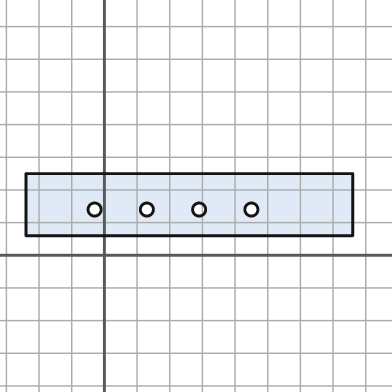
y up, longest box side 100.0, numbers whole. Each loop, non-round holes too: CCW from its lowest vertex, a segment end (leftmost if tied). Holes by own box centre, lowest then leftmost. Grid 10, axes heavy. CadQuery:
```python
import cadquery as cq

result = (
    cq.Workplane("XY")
    .moveTo(-24.0, 6.0)
    .lineTo(76.0, 6.0)
    .lineTo(76.0, 25.0)
    .lineTo(-24.0, 25.0)
    .close()
    .moveTo(-3.0, 14.0)
    .circle(2.0)
    .moveTo(13.0, 14.0)
    .circle(2.0)
    .moveTo(29.0, 14.0)
    .circle(2.0)
    .moveTo(45.0, 14.0)
    .circle(2.0)
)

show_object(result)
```